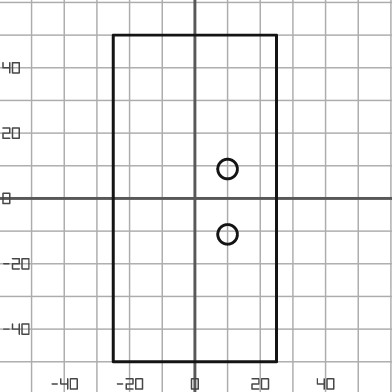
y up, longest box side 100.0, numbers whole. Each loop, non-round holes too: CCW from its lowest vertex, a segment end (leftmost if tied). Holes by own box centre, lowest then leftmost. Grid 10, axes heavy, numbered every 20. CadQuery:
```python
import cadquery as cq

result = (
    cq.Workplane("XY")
    .moveTo(-25.0, -50.0)
    .lineTo(25.0, -50.0)
    .lineTo(25.0, 50.0)
    .lineTo(-25.0, 50.0)
    .close()
    .moveTo(10.0, -11.0)
    .circle(3.0)
    .moveTo(10.0, 9.0)
    .circle(3.0)
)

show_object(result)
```